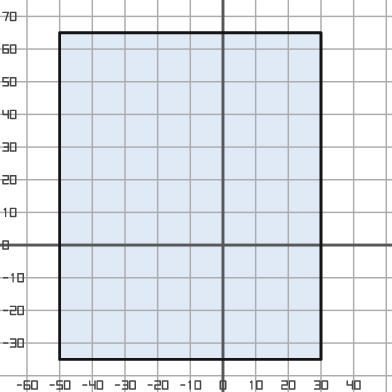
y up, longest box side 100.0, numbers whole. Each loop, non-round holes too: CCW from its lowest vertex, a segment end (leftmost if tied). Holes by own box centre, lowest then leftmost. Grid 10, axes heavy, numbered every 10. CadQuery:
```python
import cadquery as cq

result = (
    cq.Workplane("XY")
    .moveTo(-50.0, -35.0)
    .lineTo(30.0, -35.0)
    .lineTo(30.0, 65.0)
    .lineTo(-50.0, 65.0)
    .close()
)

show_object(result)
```